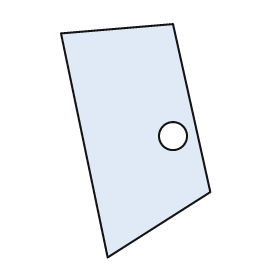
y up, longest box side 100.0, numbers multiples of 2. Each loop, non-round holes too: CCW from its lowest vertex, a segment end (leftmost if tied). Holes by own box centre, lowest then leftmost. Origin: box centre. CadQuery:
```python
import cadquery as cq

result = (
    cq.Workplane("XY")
    .moveTo(-12.0, -50.0)
    .lineTo(32.0, -22.0)
    .lineTo(16.0, 50.0)
    .lineTo(-32.0, 46.0)
    .close()
    .moveTo(16.0, 2.0)
    .circle(6.0)
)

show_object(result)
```